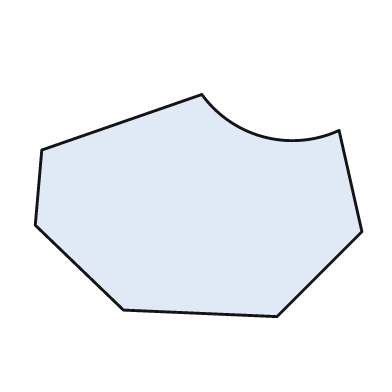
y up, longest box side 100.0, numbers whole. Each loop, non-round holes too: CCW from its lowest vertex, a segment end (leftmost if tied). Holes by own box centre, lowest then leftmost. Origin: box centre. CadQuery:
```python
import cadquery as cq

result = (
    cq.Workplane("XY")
    .moveTo(24.0, -34.0)
    .lineTo(50.0, -8.0)
    .lineTo(43.0, 23.0)
    .threePointArc((20.0, 21.0), (1.0, 34.0))
    .lineTo(-48.0, 17.0)
    .lineTo(-50.0, -6.0)
    .lineTo(-23.0, -32.0)
    .close()
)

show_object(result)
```